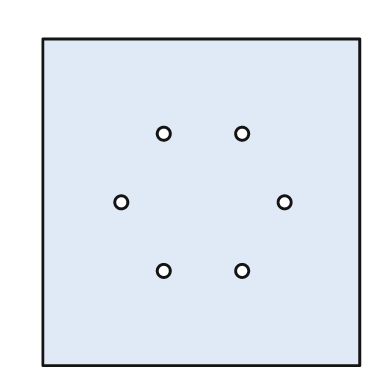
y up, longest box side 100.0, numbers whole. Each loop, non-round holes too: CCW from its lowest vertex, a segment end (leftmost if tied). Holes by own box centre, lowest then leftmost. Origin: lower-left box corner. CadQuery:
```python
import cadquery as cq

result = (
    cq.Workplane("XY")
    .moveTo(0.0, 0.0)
    .lineTo(97.0, 0.0)
    .lineTo(97.0, 100.0)
    .lineTo(0.0, 100.0)
    .close()
    .moveTo(37.0, 29.0)
    .circle(2.0)
    .moveTo(61.0, 29.0)
    .circle(2.0)
    .moveTo(24.0, 50.0)
    .circle(2.0)
    .moveTo(74.0, 50.0)
    .circle(2.0)
    .moveTo(37.0, 71.0)
    .circle(2.0)
    .moveTo(61.0, 71.0)
    .circle(2.0)
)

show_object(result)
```